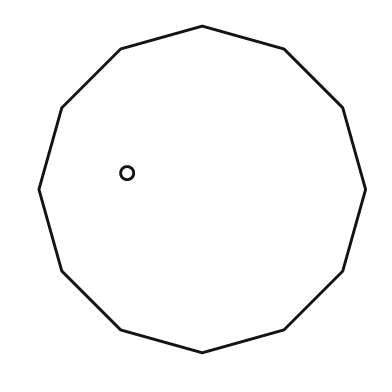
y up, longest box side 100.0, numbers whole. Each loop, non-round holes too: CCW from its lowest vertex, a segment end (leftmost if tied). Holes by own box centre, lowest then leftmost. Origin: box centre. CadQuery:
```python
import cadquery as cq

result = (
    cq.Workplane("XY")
    .moveTo(0.0, -50.0)
    .lineTo(25.0, -43.0)
    .lineTo(43.0, -25.0)
    .lineTo(50.0, 0.0)
    .lineTo(43.0, 25.0)
    .lineTo(25.0, 43.0)
    .lineTo(0.0, 50.0)
    .lineTo(-25.0, 43.0)
    .lineTo(-43.0, 25.0)
    .lineTo(-50.0, 0.0)
    .lineTo(-43.0, -25.0)
    .lineTo(-25.0, -43.0)
    .close()
    .moveTo(-23.0, 5.0)
    .circle(2.0)
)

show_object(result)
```